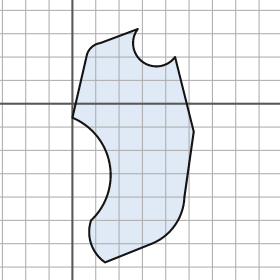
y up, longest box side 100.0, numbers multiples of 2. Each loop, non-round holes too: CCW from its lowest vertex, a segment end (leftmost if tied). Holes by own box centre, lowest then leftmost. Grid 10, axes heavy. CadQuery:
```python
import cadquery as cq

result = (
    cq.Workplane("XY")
    .moveTo(14.0, -68.0)
    .lineTo(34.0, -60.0)
    .threePointArc((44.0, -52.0), (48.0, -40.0))
    .lineTo(52.0, -12.0)
    .lineTo(44.0, 20.0)
    .threePointArc((30.0, 18.0), (28.0, 32.0))
    .lineTo(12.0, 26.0)
    .threePointArc((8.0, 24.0), (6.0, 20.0))
    .lineTo(0.0, -6.0)
    .threePointArc((16.0, -26.0), (8.0, -50.0))
    .threePointArc((8.0, -60.0), (14.0, -68.0))
    .close()
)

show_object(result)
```